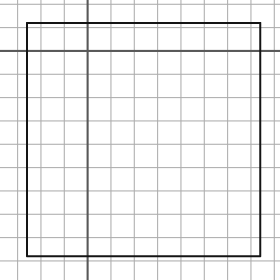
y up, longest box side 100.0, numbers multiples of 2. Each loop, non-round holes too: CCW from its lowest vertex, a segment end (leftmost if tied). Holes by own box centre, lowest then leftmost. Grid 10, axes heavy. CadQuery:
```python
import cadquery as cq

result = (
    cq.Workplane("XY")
    .moveTo(-26.0, -88.0)
    .lineTo(74.0, -88.0)
    .lineTo(74.0, 12.0)
    .lineTo(-26.0, 12.0)
    .close()
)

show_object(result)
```